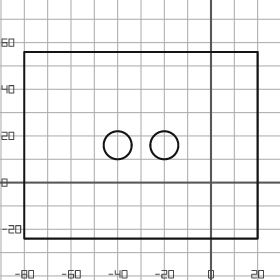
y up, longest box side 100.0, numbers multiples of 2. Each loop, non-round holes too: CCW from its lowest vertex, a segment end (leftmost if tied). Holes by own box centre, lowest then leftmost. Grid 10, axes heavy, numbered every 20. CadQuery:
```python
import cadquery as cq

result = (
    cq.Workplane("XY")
    .moveTo(-80.0, -24.0)
    .lineTo(20.0, -24.0)
    .lineTo(20.0, 56.0)
    .lineTo(-80.0, 56.0)
    .close()
    .moveTo(-40.0, 16.0)
    .circle(6.0)
    .moveTo(-20.0, 16.0)
    .circle(6.0)
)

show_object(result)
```